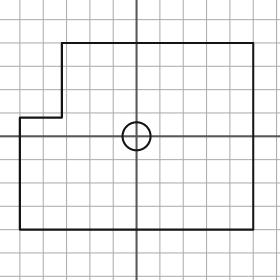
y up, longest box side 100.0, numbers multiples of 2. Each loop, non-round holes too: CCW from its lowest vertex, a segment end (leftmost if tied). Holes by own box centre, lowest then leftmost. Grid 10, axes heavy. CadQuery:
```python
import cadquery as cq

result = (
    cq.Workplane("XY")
    .moveTo(-50.0, -40.0)
    .lineTo(50.0, -40.0)
    .lineTo(50.0, 40.0)
    .lineTo(-32.0, 40.0)
    .lineTo(-32.0, 8.0)
    .lineTo(-50.0, 8.0)
    .close()
    .moveTo(0.0, 0.0)
    .circle(6.0)
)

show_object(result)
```